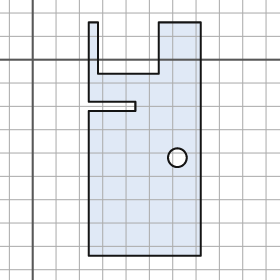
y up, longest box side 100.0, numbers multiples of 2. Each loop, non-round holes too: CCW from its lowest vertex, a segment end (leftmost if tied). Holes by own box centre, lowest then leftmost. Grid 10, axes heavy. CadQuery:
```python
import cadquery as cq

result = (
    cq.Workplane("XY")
    .moveTo(24.0, -84.0)
    .lineTo(72.0, -84.0)
    .lineTo(72.0, 16.0)
    .lineTo(54.0, 16.0)
    .lineTo(54.0, -6.0)
    .lineTo(28.0, -6.0)
    .lineTo(28.0, 16.0)
    .lineTo(24.0, 16.0)
    .lineTo(24.0, -18.0)
    .lineTo(44.0, -18.0)
    .lineTo(44.0, -22.0)
    .lineTo(24.0, -22.0)
    .close()
    .moveTo(62.0, -42.0)
    .circle(4.0)
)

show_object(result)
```